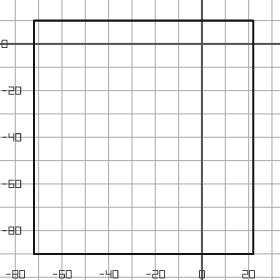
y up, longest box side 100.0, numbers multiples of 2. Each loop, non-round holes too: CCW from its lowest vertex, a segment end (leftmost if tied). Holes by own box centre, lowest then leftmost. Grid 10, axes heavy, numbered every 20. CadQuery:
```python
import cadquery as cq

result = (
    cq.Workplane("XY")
    .moveTo(-72.0, -90.0)
    .lineTo(22.0, -90.0)
    .lineTo(22.0, 10.0)
    .lineTo(-72.0, 10.0)
    .close()
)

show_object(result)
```